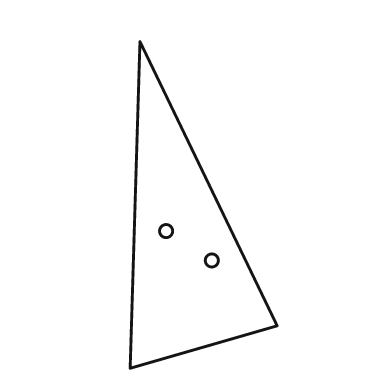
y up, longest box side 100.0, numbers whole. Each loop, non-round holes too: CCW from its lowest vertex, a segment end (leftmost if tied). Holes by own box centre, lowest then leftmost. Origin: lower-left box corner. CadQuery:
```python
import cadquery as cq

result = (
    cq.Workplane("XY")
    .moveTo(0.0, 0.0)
    .lineTo(45.0, 13.0)
    .lineTo(3.0, 100.0)
    .close()
    .moveTo(25.0, 33.0)
    .circle(2.0)
    .moveTo(11.0, 42.0)
    .circle(2.0)
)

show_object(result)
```